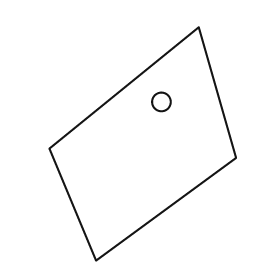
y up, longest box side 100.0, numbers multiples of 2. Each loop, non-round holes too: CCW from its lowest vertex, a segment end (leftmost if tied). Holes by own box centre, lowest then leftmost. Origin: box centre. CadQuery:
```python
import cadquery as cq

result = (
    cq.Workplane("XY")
    .moveTo(-20.0, -50.0)
    .lineTo(40.0, -6.0)
    .lineTo(24.0, 50.0)
    .lineTo(-40.0, -2.0)
    .close()
    .moveTo(8.0, 18.0)
    .circle(4.0)
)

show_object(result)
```